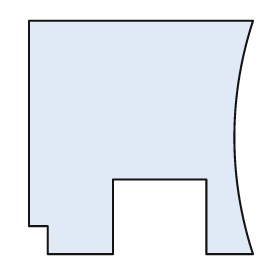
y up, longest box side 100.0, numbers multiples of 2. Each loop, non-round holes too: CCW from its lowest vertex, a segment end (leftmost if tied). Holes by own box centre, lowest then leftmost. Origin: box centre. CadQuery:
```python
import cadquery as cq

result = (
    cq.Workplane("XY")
    .moveTo(-40.0, -50.0)
    .lineTo(-12.0, -50.0)
    .lineTo(-12.0, -18.0)
    .lineTo(28.0, -18.0)
    .lineTo(28.0, -50.0)
    .lineTo(48.0, -50.0)
    .threePointArc((40.0, 0.0), (48.0, 50.0))
    .lineTo(-48.0, 50.0)
    .lineTo(-48.0, -38.0)
    .lineTo(-40.0, -38.0)
    .close()
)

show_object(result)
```